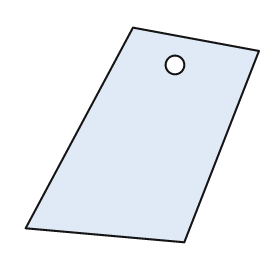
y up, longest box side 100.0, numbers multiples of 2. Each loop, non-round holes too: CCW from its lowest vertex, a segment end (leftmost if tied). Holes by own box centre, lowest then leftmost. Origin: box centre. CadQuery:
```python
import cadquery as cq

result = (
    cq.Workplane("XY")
    .moveTo(18.0, -46.0)
    .lineTo(50.0, 36.0)
    .lineTo(-4.0, 46.0)
    .lineTo(-50.0, -40.0)
    .close()
    .moveTo(14.0, 30.0)
    .circle(4.0)
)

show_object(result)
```